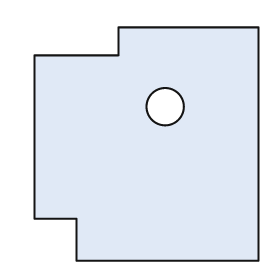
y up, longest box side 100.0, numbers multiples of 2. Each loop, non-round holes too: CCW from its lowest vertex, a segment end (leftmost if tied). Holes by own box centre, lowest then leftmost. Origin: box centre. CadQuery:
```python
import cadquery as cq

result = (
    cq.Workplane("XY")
    .moveTo(-30.0, -50.0)
    .lineTo(48.0, -50.0)
    .lineTo(48.0, 50.0)
    .lineTo(-12.0, 50.0)
    .lineTo(-12.0, 38.0)
    .lineTo(-48.0, 38.0)
    .lineTo(-48.0, -32.0)
    .lineTo(-30.0, -32.0)
    .close()
    .moveTo(8.0, 16.0)
    .circle(8.0)
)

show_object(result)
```